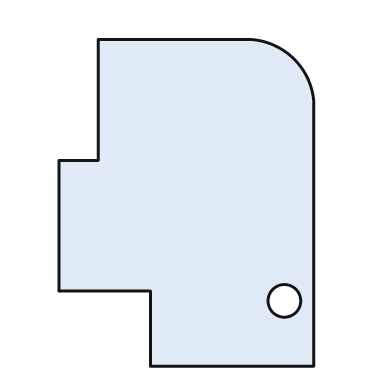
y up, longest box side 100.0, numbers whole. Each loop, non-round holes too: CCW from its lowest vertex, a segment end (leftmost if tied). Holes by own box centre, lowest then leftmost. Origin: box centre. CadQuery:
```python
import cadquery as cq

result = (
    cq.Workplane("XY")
    .moveTo(-11.0, -50.0)
    .lineTo(39.0, -50.0)
    .lineTo(39.0, 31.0)
    .threePointArc((33.0, 44.0), (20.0, 50.0))
    .lineTo(-27.0, 50.0)
    .lineTo(-27.0, 13.0)
    .lineTo(-39.0, 13.0)
    .lineTo(-39.0, -27.0)
    .lineTo(-11.0, -27.0)
    .close()
    .moveTo(30.0, -30.0)
    .circle(5.0)
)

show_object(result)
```